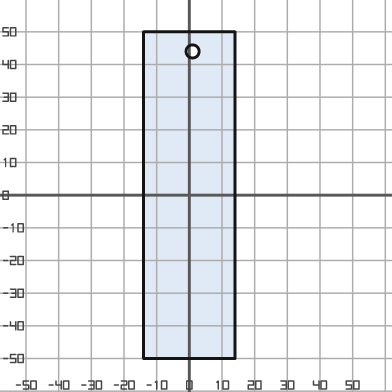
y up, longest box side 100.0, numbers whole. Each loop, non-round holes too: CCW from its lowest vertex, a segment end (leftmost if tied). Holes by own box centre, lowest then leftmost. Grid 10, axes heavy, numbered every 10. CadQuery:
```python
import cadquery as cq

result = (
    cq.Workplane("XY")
    .moveTo(-14.0, -50.0)
    .lineTo(14.0, -50.0)
    .lineTo(14.0, 50.0)
    .lineTo(-14.0, 50.0)
    .close()
    .moveTo(1.0, 44.0)
    .circle(2.0)
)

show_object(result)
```